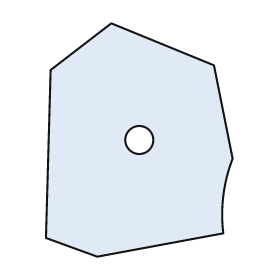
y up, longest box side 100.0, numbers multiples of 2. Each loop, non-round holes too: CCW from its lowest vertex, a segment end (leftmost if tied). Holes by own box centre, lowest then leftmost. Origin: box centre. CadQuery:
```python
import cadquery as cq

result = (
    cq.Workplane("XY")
    .moveTo(-18.0, -50.0)
    .lineTo(36.0, -40.0)
    .threePointArc((36.0, -24.0), (40.0, -8.0))
    .lineTo(32.0, 32.0)
    .lineTo(-12.0, 50.0)
    .lineTo(-38.0, 30.0)
    .lineTo(-40.0, -42.0)
    .close()
    .moveTo(0.0, 0.0)
    .circle(6.0)
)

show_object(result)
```